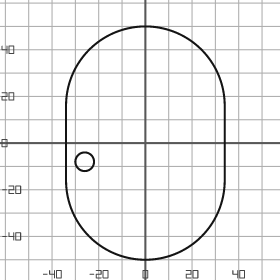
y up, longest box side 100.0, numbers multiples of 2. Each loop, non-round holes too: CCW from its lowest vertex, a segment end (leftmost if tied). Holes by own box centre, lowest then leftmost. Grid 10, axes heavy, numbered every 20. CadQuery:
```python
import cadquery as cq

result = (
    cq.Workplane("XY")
    .moveTo(-34.0, -16.0)
    .threePointArc((0.0, -50.0), (34.0, -16.0))
    .lineTo(34.0, 16.0)
    .threePointArc((0.0, 50.0), (-34.0, 16.0))
    .close()
    .moveTo(-26.0, -8.0)
    .circle(4.0)
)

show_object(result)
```